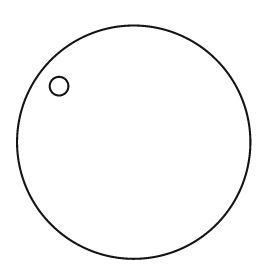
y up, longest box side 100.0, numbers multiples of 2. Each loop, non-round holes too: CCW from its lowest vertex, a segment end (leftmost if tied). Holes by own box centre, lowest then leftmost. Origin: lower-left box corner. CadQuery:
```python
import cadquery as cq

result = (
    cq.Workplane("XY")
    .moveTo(50.0, 50.0)
    .circle(50.0)
    .moveTo(18.0, 74.0)
    .circle(4.0)
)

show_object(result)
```